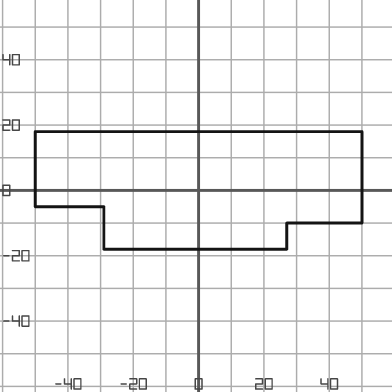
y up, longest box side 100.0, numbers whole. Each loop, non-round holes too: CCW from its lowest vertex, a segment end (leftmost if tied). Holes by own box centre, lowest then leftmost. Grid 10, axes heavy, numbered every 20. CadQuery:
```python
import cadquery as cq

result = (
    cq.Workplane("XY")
    .moveTo(-29.0, -18.0)
    .lineTo(27.0, -18.0)
    .lineTo(27.0, -10.0)
    .lineTo(50.0, -10.0)
    .lineTo(50.0, 18.0)
    .lineTo(-50.0, 18.0)
    .lineTo(-50.0, -5.0)
    .lineTo(-29.0, -5.0)
    .close()
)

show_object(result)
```